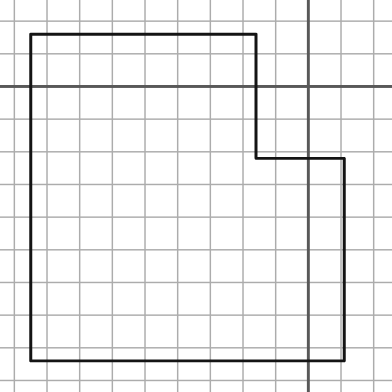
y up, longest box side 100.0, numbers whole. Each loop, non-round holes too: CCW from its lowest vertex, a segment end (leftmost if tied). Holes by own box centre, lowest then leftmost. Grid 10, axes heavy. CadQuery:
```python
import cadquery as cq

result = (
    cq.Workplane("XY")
    .moveTo(-85.0, -84.0)
    .lineTo(11.0, -84.0)
    .lineTo(11.0, -22.0)
    .lineTo(-16.0, -22.0)
    .lineTo(-16.0, 16.0)
    .lineTo(-85.0, 16.0)
    .close()
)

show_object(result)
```